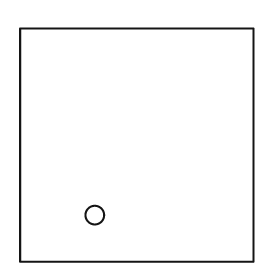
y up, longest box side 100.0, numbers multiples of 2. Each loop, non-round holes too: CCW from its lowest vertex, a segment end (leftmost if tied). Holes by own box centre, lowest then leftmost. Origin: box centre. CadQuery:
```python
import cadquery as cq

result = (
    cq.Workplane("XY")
    .moveTo(-50.0, -50.0)
    .lineTo(50.0, -50.0)
    .lineTo(50.0, 50.0)
    .lineTo(-50.0, 50.0)
    .close()
    .moveTo(-18.0, -30.0)
    .circle(4.0)
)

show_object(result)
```